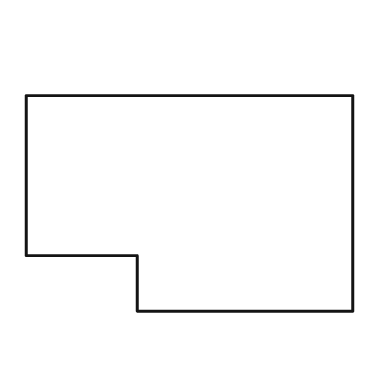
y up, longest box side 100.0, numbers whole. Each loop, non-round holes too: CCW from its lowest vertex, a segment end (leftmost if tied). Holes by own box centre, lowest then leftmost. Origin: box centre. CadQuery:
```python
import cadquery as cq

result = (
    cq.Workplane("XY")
    .moveTo(-16.0, -33.0)
    .lineTo(50.0, -33.0)
    .lineTo(50.0, 33.0)
    .lineTo(-50.0, 33.0)
    .lineTo(-50.0, -16.0)
    .lineTo(-16.0, -16.0)
    .close()
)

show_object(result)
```